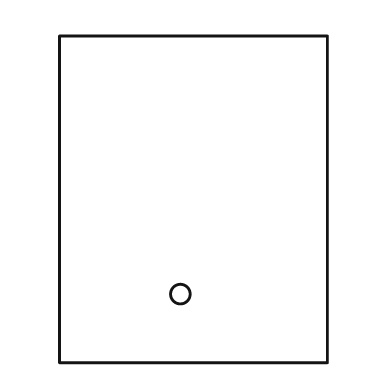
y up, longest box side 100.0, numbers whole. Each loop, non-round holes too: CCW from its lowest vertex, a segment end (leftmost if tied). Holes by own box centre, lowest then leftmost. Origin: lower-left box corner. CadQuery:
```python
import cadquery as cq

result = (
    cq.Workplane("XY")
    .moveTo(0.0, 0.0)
    .lineTo(82.0, 0.0)
    .lineTo(82.0, 100.0)
    .lineTo(0.0, 100.0)
    .close()
    .moveTo(37.0, 21.0)
    .circle(3.0)
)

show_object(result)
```